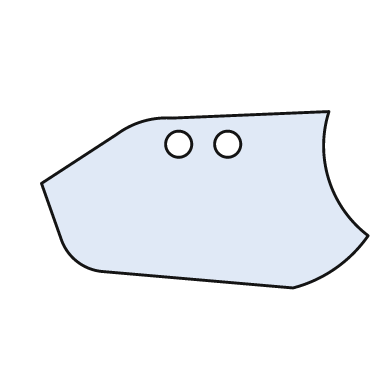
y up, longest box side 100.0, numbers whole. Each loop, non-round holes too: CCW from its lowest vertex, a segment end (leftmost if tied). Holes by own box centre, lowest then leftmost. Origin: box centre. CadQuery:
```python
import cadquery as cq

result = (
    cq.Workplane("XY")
    .moveTo(27.0, -27.0)
    .threePointArc((40.0, -21.0), (50.0, -11.0))
    .threePointArc((38.0, 6.0), (38.0, 27.0))
    .lineTo(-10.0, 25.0)
    .threePointArc((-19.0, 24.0), (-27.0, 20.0))
    .lineTo(-50.0, 5.0)
    .lineTo(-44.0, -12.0)
    .threePointArc((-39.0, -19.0), (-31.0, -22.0))
    .close()
    .moveTo(-8.0, 17.0)
    .circle(4.0)
    .moveTo(7.0, 17.0)
    .circle(4.0)
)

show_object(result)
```